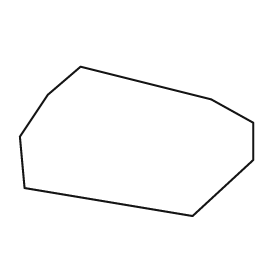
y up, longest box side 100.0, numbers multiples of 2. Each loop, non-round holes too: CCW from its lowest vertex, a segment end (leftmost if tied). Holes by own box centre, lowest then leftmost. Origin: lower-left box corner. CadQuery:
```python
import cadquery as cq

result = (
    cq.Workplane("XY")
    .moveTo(74.0, 0.0)
    .lineTo(100.0, 24.0)
    .lineTo(100.0, 40.0)
    .lineTo(82.0, 50.0)
    .lineTo(26.0, 64.0)
    .lineTo(12.0, 52.0)
    .lineTo(0.0, 34.0)
    .lineTo(2.0, 12.0)
    .close()
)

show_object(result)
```